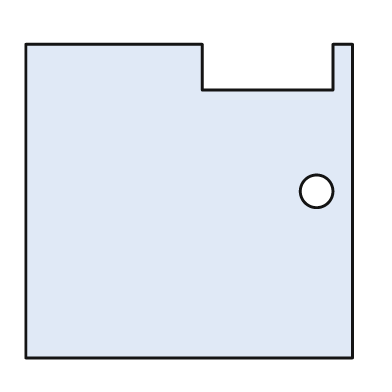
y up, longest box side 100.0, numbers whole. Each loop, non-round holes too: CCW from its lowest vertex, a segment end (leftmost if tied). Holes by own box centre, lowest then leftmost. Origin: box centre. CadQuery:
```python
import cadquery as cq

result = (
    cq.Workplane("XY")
    .moveTo(-50.0, -48.0)
    .lineTo(50.0, -48.0)
    .lineTo(50.0, 48.0)
    .lineTo(44.0, 48.0)
    .lineTo(44.0, 34.0)
    .lineTo(4.0, 34.0)
    .lineTo(4.0, 48.0)
    .lineTo(-50.0, 48.0)
    .close()
    .moveTo(39.0, 3.0)
    .circle(5.0)
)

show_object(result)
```